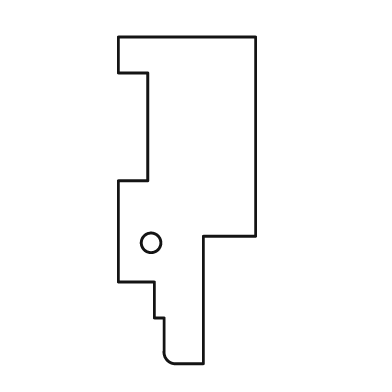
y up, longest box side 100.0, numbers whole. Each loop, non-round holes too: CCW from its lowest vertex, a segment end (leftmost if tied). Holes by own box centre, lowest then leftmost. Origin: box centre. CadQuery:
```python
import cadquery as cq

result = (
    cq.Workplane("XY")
    .moveTo(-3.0, -50.0)
    .lineTo(5.0, -50.0)
    .lineTo(5.0, -11.0)
    .lineTo(21.0, -11.0)
    .lineTo(21.0, 50.0)
    .lineTo(-21.0, 50.0)
    .lineTo(-21.0, 39.0)
    .lineTo(-12.0, 39.0)
    .lineTo(-12.0, 6.0)
    .lineTo(-21.0, 6.0)
    .lineTo(-21.0, -25.0)
    .lineTo(-10.0, -25.0)
    .lineTo(-10.0, -36.0)
    .lineTo(-7.0, -36.0)
    .lineTo(-7.0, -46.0)
    .threePointArc((-6.0, -49.0), (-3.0, -50.0))
    .close()
    .moveTo(-11.0, -13.0)
    .circle(3.0)
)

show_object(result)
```